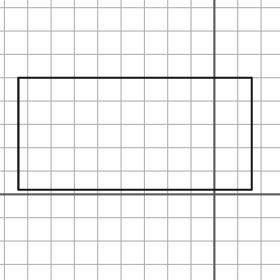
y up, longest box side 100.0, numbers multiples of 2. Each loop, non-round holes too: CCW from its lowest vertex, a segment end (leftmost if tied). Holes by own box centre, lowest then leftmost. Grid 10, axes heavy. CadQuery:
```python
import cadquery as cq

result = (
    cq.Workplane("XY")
    .moveTo(-84.0, 2.0)
    .lineTo(16.0, 2.0)
    .lineTo(16.0, 50.0)
    .lineTo(-84.0, 50.0)
    .close()
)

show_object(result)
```